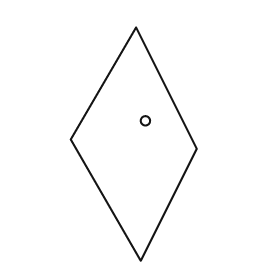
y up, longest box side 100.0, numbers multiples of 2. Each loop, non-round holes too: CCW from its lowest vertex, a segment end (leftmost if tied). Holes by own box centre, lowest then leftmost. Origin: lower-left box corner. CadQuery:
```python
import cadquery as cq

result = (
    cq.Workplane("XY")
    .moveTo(30.0, 0.0)
    .lineTo(54.0, 48.0)
    .lineTo(28.0, 100.0)
    .lineTo(0.0, 52.0)
    .close()
    .moveTo(32.0, 60.0)
    .circle(2.0)
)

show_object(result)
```